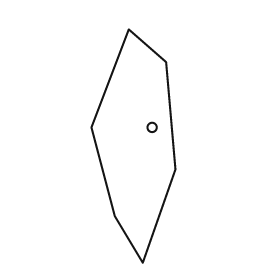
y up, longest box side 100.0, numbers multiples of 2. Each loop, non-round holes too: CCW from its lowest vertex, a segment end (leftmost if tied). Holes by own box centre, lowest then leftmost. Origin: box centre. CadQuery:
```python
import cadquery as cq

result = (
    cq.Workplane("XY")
    .moveTo(4.0, -50.0)
    .lineTo(18.0, -10.0)
    .lineTo(14.0, 36.0)
    .lineTo(-2.0, 50.0)
    .lineTo(-18.0, 8.0)
    .lineTo(-8.0, -30.0)
    .close()
    .moveTo(8.0, 8.0)
    .circle(2.0)
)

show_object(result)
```